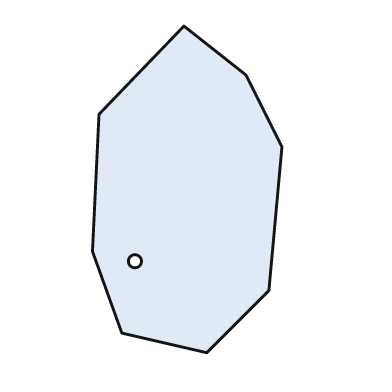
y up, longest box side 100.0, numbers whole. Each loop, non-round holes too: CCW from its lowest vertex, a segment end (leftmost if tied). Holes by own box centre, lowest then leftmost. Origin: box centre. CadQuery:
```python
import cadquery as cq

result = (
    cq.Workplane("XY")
    .moveTo(6.0, -50.0)
    .lineTo(25.0, -31.0)
    .lineTo(29.0, 13.0)
    .lineTo(18.0, 35.0)
    .lineTo(-1.0, 50.0)
    .lineTo(-27.0, 23.0)
    .lineTo(-29.0, -19.0)
    .lineTo(-20.0, -44.0)
    .close()
    .moveTo(-16.0, -22.0)
    .circle(2.0)
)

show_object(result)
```